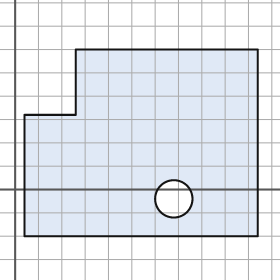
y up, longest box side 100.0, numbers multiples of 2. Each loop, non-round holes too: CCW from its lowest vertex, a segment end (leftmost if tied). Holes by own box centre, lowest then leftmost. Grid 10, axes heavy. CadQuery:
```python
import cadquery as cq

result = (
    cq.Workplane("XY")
    .moveTo(4.0, -20.0)
    .lineTo(104.0, -20.0)
    .lineTo(104.0, 60.0)
    .lineTo(26.0, 60.0)
    .lineTo(26.0, 32.0)
    .lineTo(4.0, 32.0)
    .close()
    .moveTo(68.0, -4.0)
    .circle(8.0)
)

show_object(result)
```